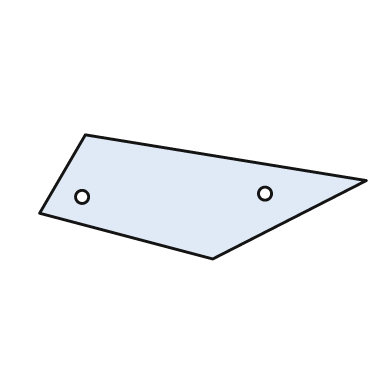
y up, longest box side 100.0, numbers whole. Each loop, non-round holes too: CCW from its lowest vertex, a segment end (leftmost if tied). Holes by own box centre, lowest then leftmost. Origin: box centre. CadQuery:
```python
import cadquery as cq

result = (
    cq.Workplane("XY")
    .moveTo(3.0, -19.0)
    .lineTo(50.0, 5.0)
    .lineTo(-36.0, 19.0)
    .lineTo(-50.0, -5.0)
    .close()
    .moveTo(-37.0, 0.0)
    .circle(2.0)
    .moveTo(19.0, 1.0)
    .circle(2.0)
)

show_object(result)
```